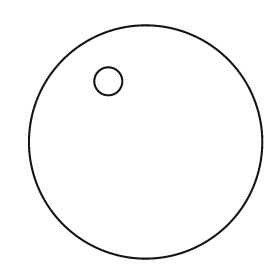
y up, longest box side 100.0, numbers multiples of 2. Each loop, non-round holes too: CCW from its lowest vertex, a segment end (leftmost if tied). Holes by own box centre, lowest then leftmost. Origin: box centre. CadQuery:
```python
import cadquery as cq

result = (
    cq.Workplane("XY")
    .moveTo(0.0, 0.0)
    .circle(50.0)
    .moveTo(-16.0, 26.0)
    .circle(6.0)
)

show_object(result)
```